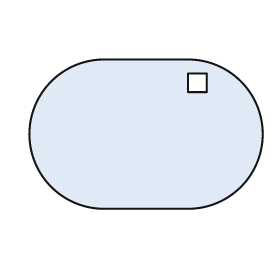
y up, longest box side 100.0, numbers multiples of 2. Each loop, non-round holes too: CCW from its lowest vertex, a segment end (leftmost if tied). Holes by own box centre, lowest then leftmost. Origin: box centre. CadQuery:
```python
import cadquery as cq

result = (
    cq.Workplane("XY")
    .moveTo(-18.0, -32.0)
    .lineTo(18.0, -32.0)
    .threePointArc((50.0, 0.0), (18.0, 32.0))
    .lineTo(-18.0, 32.0)
    .threePointArc((-50.0, 0.0), (-18.0, -32.0))
    .close()
    .moveTo(18.0, 18.0)
    .lineTo(26.0, 18.0)
    .lineTo(26.0, 26.0)
    .lineTo(18.0, 26.0)
    .close()
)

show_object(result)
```